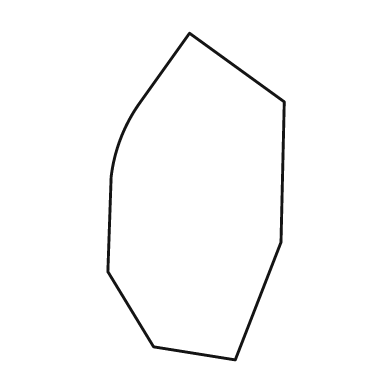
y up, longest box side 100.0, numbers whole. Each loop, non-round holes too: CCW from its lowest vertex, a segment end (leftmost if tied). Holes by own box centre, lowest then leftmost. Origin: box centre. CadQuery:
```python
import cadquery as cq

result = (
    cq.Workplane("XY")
    .moveTo(12.0, -50.0)
    .lineTo(26.0, -14.0)
    .lineTo(27.0, 29.0)
    .lineTo(-2.0, 50.0)
    .lineTo(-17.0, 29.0)
    .threePointArc((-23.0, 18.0), (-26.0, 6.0))
    .lineTo(-27.0, -23.0)
    .lineTo(-13.0, -46.0)
    .close()
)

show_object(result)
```